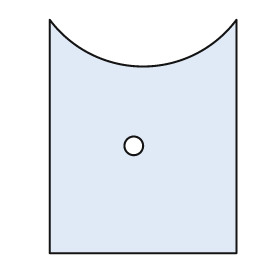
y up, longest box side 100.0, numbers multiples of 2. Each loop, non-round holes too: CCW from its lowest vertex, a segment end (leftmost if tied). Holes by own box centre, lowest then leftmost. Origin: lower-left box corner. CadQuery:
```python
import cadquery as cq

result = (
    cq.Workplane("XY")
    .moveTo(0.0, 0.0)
    .lineTo(80.0, 0.0)
    .lineTo(80.0, 100.0)
    .threePointArc((40.0, 80.0), (0.0, 100.0))
    .close()
    .moveTo(36.0, 46.0)
    .circle(4.0)
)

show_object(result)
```